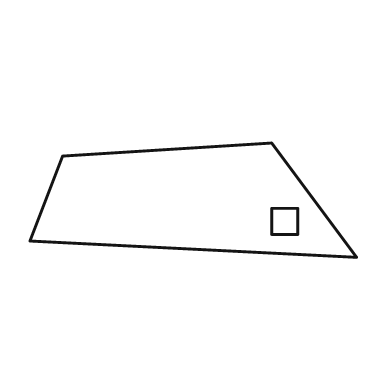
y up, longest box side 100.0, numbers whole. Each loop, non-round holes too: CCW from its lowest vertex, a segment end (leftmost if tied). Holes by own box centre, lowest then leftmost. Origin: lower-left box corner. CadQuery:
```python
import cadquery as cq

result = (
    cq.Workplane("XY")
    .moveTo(100.0, 0.0)
    .lineTo(74.0, 35.0)
    .lineTo(10.0, 31.0)
    .lineTo(0.0, 5.0)
    .close()
    .moveTo(74.0, 7.0)
    .lineTo(82.0, 7.0)
    .lineTo(82.0, 15.0)
    .lineTo(74.0, 15.0)
    .close()
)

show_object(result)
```